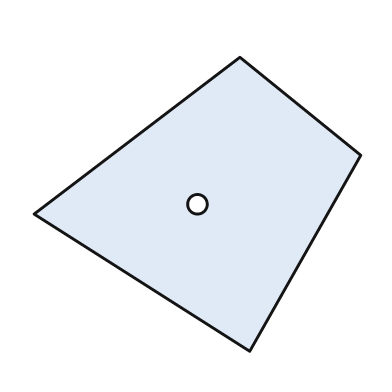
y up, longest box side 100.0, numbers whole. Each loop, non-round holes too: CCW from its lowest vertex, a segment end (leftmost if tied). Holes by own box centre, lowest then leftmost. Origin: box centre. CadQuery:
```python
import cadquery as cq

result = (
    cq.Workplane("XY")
    .moveTo(16.0, -45.0)
    .lineTo(50.0, 15.0)
    .lineTo(13.0, 45.0)
    .lineTo(-50.0, -3.0)
    .close()
    .moveTo(0.0, 0.0)
    .circle(3.0)
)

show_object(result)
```